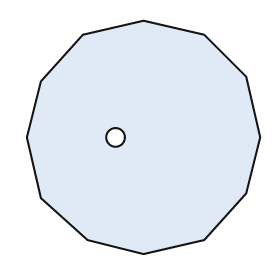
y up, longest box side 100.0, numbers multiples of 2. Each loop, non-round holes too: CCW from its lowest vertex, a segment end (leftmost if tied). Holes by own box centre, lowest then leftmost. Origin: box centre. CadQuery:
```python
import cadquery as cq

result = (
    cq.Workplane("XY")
    .moveTo(0.0, -50.0)
    .lineTo(26.0, -44.0)
    .lineTo(44.0, -24.0)
    .lineTo(50.0, 0.0)
    .lineTo(44.0, 26.0)
    .lineTo(26.0, 44.0)
    .lineTo(0.0, 50.0)
    .lineTo(-26.0, 44.0)
    .lineTo(-44.0, 24.0)
    .lineTo(-50.0, 0.0)
    .lineTo(-44.0, -26.0)
    .lineTo(-24.0, -44.0)
    .close()
    .moveTo(-12.0, 0.0)
    .circle(4.0)
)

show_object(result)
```